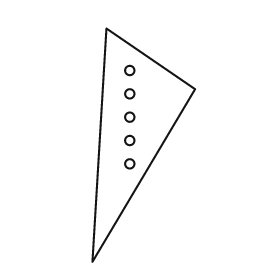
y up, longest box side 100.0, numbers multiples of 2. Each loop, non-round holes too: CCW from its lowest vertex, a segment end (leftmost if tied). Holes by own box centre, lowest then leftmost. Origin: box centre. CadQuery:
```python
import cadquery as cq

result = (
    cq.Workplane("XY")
    .moveTo(-22.0, -50.0)
    .lineTo(22.0, 24.0)
    .lineTo(-16.0, 50.0)
    .close()
    .moveTo(-6.0, -8.0)
    .circle(2.0)
    .moveTo(-6.0, 2.0)
    .circle(2.0)
    .moveTo(-6.0, 12.0)
    .circle(2.0)
    .moveTo(-6.0, 22.0)
    .circle(2.0)
    .moveTo(-6.0, 32.0)
    .circle(2.0)
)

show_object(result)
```